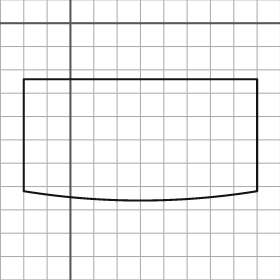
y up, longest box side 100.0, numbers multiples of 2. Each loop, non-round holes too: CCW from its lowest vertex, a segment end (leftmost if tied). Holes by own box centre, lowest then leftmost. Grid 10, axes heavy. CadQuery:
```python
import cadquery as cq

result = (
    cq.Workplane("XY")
    .moveTo(-20.0, -72.0)
    .threePointArc((30.0, -76.0), (80.0, -72.0))
    .lineTo(80.0, -24.0)
    .lineTo(-20.0, -24.0)
    .close()
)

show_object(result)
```